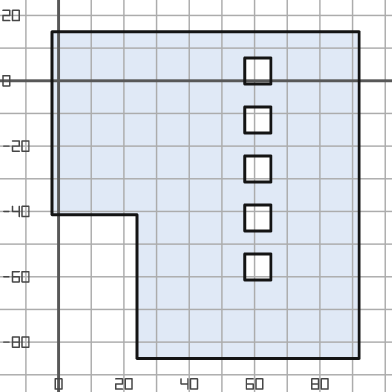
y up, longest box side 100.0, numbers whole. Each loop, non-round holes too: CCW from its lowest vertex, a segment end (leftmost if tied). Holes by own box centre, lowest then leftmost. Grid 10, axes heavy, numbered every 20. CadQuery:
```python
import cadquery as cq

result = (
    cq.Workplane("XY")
    .moveTo(24.0, -85.0)
    .lineTo(92.0, -85.0)
    .lineTo(92.0, 15.0)
    .lineTo(-2.0, 15.0)
    .lineTo(-2.0, -41.0)
    .lineTo(24.0, -41.0)
    .close()
    .moveTo(57.0, -61.0)
    .lineTo(65.0, -61.0)
    .lineTo(65.0, -53.0)
    .lineTo(57.0, -53.0)
    .close()
    .moveTo(57.0, -46.0)
    .lineTo(65.0, -46.0)
    .lineTo(65.0, -38.0)
    .lineTo(57.0, -38.0)
    .close()
    .moveTo(57.0, -31.0)
    .lineTo(65.0, -31.0)
    .lineTo(65.0, -23.0)
    .lineTo(57.0, -23.0)
    .close()
    .moveTo(57.0, -16.0)
    .lineTo(65.0, -16.0)
    .lineTo(65.0, -8.0)
    .lineTo(57.0, -8.0)
    .close()
    .moveTo(57.0, -1.0)
    .lineTo(65.0, -1.0)
    .lineTo(65.0, 7.0)
    .lineTo(57.0, 7.0)
    .close()
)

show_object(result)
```